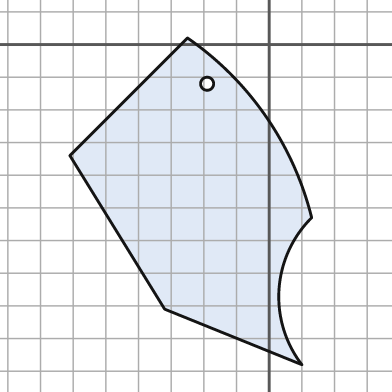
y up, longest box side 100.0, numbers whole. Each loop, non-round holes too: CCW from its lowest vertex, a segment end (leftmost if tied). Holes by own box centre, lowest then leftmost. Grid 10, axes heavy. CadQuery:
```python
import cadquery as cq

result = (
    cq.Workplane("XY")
    .moveTo(10.0, -98.0)
    .threePointArc((3.0, -75.0), (13.0, -53.0))
    .threePointArc((-1.0, -22.0), (-25.0, 2.0))
    .lineTo(-61.0, -34.0)
    .lineTo(-32.0, -81.0)
    .close()
    .moveTo(-19.0, -12.0)
    .circle(2.0)
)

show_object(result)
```